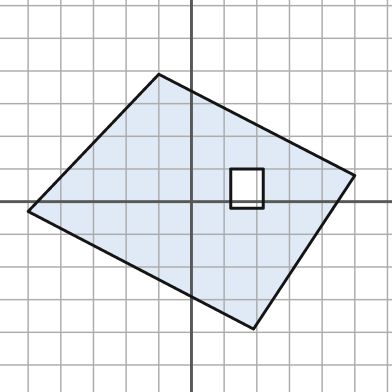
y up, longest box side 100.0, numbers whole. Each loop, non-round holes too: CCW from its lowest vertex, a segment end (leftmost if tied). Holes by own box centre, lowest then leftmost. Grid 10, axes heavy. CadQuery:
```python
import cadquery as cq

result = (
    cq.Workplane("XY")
    .moveTo(19.0, -39.0)
    .lineTo(50.0, 8.0)
    .lineTo(-10.0, 39.0)
    .lineTo(-50.0, -3.0)
    .close()
    .moveTo(12.0, -2.0)
    .lineTo(22.0, -2.0)
    .lineTo(22.0, 10.0)
    .lineTo(12.0, 10.0)
    .close()
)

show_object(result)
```